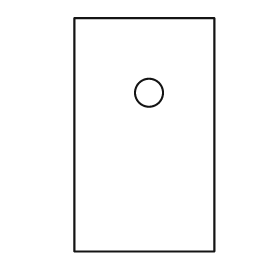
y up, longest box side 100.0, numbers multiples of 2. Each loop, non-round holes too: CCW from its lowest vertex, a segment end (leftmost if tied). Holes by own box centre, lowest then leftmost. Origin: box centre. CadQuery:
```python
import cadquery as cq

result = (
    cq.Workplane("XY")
    .moveTo(-30.0, -50.0)
    .lineTo(30.0, -50.0)
    .lineTo(30.0, 50.0)
    .lineTo(-30.0, 50.0)
    .close()
    .moveTo(2.0, 18.0)
    .circle(6.0)
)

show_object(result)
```